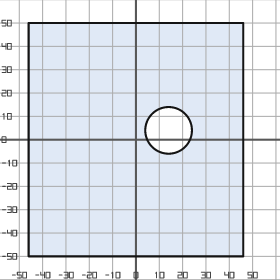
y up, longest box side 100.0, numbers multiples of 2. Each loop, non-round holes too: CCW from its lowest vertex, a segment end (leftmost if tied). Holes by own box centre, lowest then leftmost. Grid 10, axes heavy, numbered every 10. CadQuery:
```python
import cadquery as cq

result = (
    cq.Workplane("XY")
    .moveTo(-46.0, -50.0)
    .lineTo(46.0, -50.0)
    .lineTo(46.0, 50.0)
    .lineTo(-46.0, 50.0)
    .close()
    .moveTo(14.0, 4.0)
    .circle(10.0)
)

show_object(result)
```